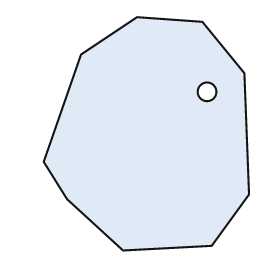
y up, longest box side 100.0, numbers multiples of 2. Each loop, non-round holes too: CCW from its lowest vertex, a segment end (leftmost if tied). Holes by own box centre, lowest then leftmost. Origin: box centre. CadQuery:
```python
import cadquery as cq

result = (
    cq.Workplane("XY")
    .moveTo(-10.0, -50.0)
    .lineTo(28.0, -48.0)
    .lineTo(44.0, -26.0)
    .lineTo(42.0, 26.0)
    .lineTo(24.0, 48.0)
    .lineTo(-4.0, 50.0)
    .lineTo(-28.0, 34.0)
    .lineTo(-44.0, -12.0)
    .lineTo(-34.0, -28.0)
    .close()
    .moveTo(26.0, 18.0)
    .circle(4.0)
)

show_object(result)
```